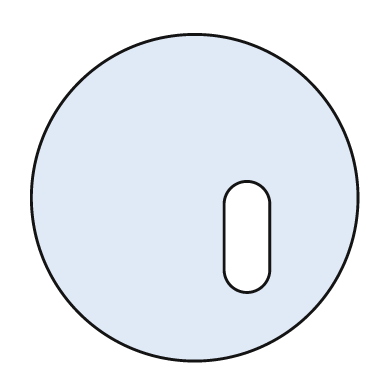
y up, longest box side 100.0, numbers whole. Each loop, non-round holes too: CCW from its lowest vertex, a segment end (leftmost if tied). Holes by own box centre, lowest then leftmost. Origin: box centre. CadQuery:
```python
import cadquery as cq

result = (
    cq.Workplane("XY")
    .moveTo(0.0, 0.0)
    .circle(50.0)
    .moveTo(9.0, -22.0)
    .threePointArc((16.0, -29.0), (23.0, -22.0))
    .lineTo(23.0, -2.0)
    .threePointArc((16.0, 5.0), (9.0, -2.0))
    .close()
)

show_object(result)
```